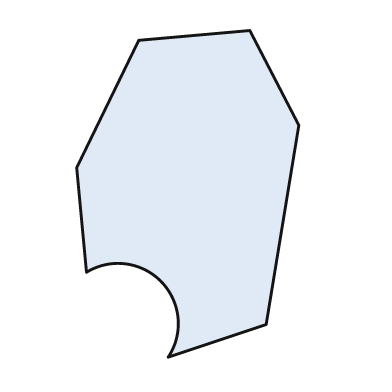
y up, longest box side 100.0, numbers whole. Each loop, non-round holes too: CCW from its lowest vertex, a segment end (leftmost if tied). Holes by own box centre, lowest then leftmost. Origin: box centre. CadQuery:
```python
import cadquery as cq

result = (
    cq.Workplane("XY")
    .moveTo(-6.0, -50.0)
    .lineTo(24.0, -40.0)
    .lineTo(34.0, 21.0)
    .lineTo(19.0, 50.0)
    .lineTo(-15.0, 47.0)
    .lineTo(-34.0, 8.0)
    .lineTo(-31.0, -24.0)
    .threePointArc((-8.0, -27.0), (-6.0, -50.0))
    .close()
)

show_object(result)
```